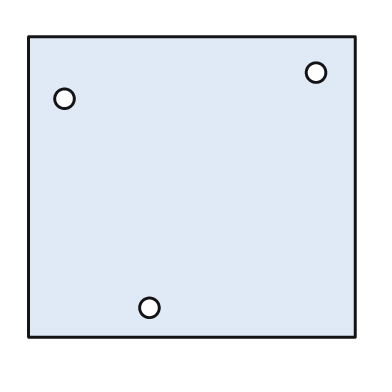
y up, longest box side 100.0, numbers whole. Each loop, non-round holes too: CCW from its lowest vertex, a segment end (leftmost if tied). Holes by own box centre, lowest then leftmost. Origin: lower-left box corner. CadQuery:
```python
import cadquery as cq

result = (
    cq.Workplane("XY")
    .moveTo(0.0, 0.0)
    .lineTo(100.0, 0.0)
    .lineTo(100.0, 92.0)
    .lineTo(0.0, 92.0)
    .close()
    .moveTo(37.0, 9.0)
    .circle(3.0)
    .moveTo(11.0, 73.0)
    .circle(3.0)
    .moveTo(88.0, 81.0)
    .circle(3.0)
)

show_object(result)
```